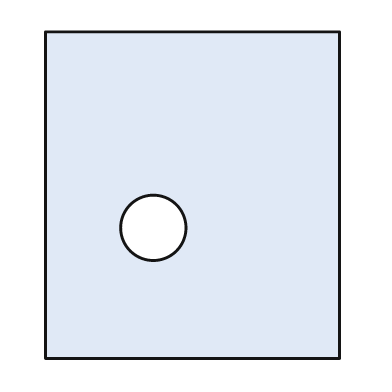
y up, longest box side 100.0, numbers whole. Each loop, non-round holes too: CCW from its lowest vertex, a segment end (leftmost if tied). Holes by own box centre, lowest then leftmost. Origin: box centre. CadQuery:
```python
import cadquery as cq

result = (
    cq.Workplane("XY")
    .moveTo(-45.0, -50.0)
    .lineTo(45.0, -50.0)
    .lineTo(45.0, 50.0)
    .lineTo(-45.0, 50.0)
    .close()
    .moveTo(-12.0, -10.0)
    .circle(10.0)
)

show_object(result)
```